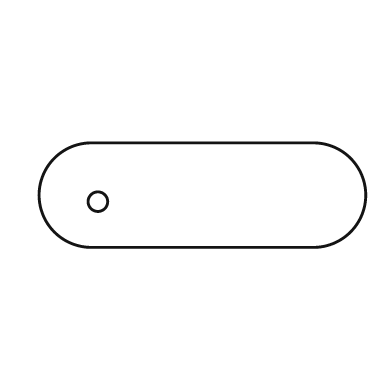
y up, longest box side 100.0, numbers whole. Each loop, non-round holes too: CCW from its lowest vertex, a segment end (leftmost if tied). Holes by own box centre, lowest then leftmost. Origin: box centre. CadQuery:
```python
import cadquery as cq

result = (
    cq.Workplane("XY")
    .moveTo(-34.0, -16.0)
    .lineTo(34.0, -16.0)
    .threePointArc((50.0, 0.0), (34.0, 16.0))
    .lineTo(-34.0, 16.0)
    .threePointArc((-50.0, 0.0), (-34.0, -16.0))
    .close()
    .moveTo(-32.0, -2.0)
    .circle(3.0)
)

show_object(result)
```